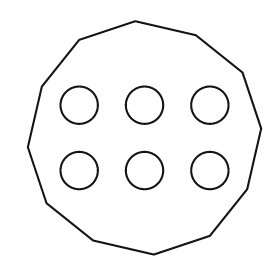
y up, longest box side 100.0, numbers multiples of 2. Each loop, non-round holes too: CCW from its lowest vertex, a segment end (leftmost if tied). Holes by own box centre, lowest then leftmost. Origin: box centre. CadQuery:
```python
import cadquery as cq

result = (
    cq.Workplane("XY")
    .moveTo(4.0, -50.0)
    .lineTo(28.0, -42.0)
    .lineTo(44.0, -22.0)
    .lineTo(50.0, 4.0)
    .lineTo(42.0, 28.0)
    .lineTo(22.0, 44.0)
    .lineTo(-4.0, 50.0)
    .lineTo(-28.0, 42.0)
    .lineTo(-44.0, 22.0)
    .lineTo(-50.0, -4.0)
    .lineTo(-42.0, -28.0)
    .lineTo(-22.0, -44.0)
    .close()
    .moveTo(-28.0, -14.0)
    .circle(8.0)
    .moveTo(0.0, -14.0)
    .circle(8.0)
    .moveTo(28.0, -14.0)
    .circle(8.0)
    .moveTo(-28.0, 14.0)
    .circle(8.0)
    .moveTo(0.0, 14.0)
    .circle(8.0)
    .moveTo(28.0, 14.0)
    .circle(8.0)
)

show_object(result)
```